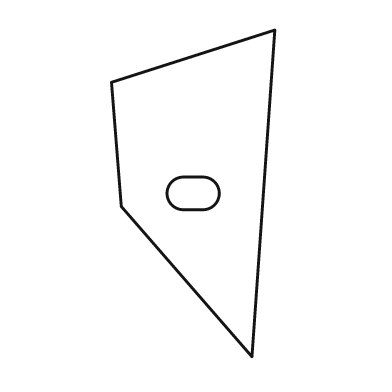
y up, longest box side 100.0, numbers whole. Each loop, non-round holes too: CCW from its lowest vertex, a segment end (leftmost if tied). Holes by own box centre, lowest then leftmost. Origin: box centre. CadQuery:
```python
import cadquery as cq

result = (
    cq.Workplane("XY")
    .moveTo(18.0, -50.0)
    .lineTo(25.0, 50.0)
    .lineTo(-25.0, 34.0)
    .lineTo(-22.0, -4.0)
    .close()
    .moveTo(-3.0, -5.0)
    .lineTo(3.0, -5.0)
    .threePointArc((8.0, 0.0), (3.0, 5.0))
    .lineTo(-3.0, 5.0)
    .threePointArc((-8.0, 0.0), (-3.0, -5.0))
    .close()
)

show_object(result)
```